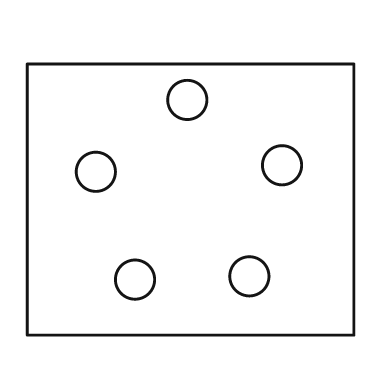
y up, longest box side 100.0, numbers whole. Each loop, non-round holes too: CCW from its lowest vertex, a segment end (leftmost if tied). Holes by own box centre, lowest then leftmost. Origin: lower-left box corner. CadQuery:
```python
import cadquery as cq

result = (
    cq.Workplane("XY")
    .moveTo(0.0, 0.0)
    .lineTo(100.0, 0.0)
    .lineTo(100.0, 83.0)
    .lineTo(0.0, 83.0)
    .close()
    .moveTo(33.0, 17.0)
    .circle(6.0)
    .moveTo(68.0, 18.0)
    .circle(6.0)
    .moveTo(21.0, 50.0)
    .circle(6.0)
    .moveTo(78.0, 52.0)
    .circle(6.0)
    .moveTo(49.0, 72.0)
    .circle(6.0)
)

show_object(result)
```